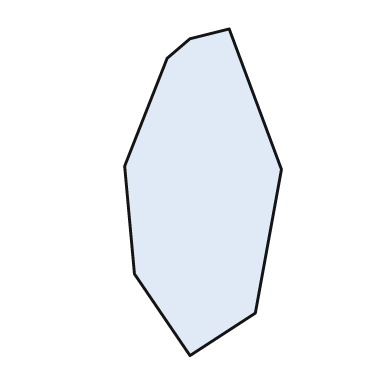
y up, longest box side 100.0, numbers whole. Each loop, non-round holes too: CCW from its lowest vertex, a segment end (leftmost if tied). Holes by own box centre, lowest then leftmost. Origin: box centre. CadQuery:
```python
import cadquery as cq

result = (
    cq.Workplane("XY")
    .moveTo(-4.0, -50.0)
    .lineTo(16.0, -37.0)
    .lineTo(24.0, 7.0)
    .lineTo(8.0, 50.0)
    .lineTo(-4.0, 47.0)
    .lineTo(-11.0, 41.0)
    .lineTo(-24.0, 8.0)
    .lineTo(-21.0, -25.0)
    .close()
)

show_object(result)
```